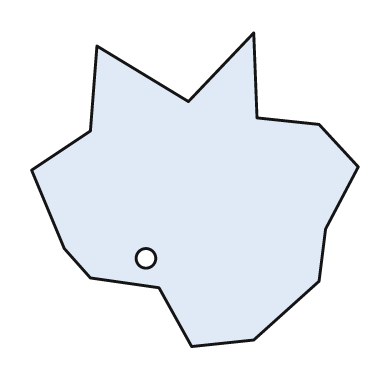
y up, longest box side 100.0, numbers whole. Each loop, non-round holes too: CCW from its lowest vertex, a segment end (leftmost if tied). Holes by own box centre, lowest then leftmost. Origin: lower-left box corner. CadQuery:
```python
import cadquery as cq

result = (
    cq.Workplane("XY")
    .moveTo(49.0, 0.0)
    .lineTo(68.0, 2.0)
    .lineTo(88.0, 20.0)
    .lineTo(90.0, 36.0)
    .lineTo(100.0, 55.0)
    .lineTo(88.0, 68.0)
    .lineTo(69.0, 70.0)
    .lineTo(68.0, 96.0)
    .lineTo(48.0, 75.0)
    .lineTo(20.0, 92.0)
    .lineTo(18.0, 66.0)
    .lineTo(0.0, 54.0)
    .lineTo(10.0, 30.0)
    .lineTo(18.0, 21.0)
    .lineTo(39.0, 18.0)
    .close()
    .moveTo(35.0, 27.0)
    .circle(3.0)
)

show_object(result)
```